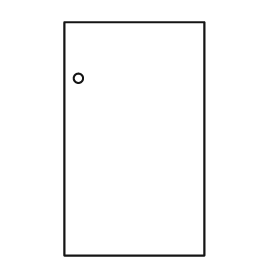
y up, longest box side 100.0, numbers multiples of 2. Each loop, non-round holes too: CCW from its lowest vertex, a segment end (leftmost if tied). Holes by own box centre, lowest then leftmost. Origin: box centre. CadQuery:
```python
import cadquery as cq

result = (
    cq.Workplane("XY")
    .moveTo(-30.0, -50.0)
    .lineTo(30.0, -50.0)
    .lineTo(30.0, 50.0)
    .lineTo(-30.0, 50.0)
    .close()
    .moveTo(-24.0, 26.0)
    .circle(2.0)
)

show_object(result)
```